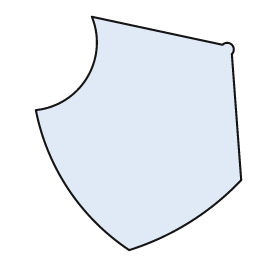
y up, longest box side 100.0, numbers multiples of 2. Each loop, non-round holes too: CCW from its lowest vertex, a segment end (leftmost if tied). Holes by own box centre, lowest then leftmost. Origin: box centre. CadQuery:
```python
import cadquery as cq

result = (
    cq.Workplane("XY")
    .moveTo(-4.0, -50.0)
    .threePointArc((22.0, -38.0), (44.0, -20.0))
    .lineTo(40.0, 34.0)
    .threePointArc((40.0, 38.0), (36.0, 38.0))
    .lineTo(-20.0, 50.0)
    .threePointArc((-22.0, 24.0), (-44.0, 10.0))
    .threePointArc((-30.0, -24.0), (-4.0, -50.0))
    .close()
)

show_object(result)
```